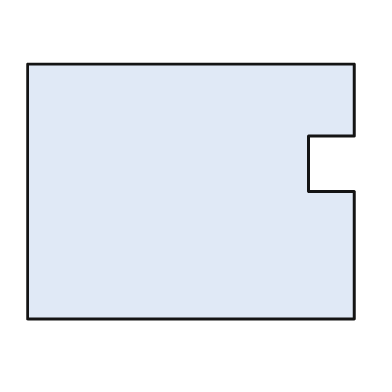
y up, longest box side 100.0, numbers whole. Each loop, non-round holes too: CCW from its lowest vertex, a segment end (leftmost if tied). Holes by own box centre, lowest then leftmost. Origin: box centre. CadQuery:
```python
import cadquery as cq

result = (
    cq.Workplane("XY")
    .moveTo(-50.0, -39.0)
    .lineTo(50.0, -39.0)
    .lineTo(50.0, 0.0)
    .lineTo(36.0, 0.0)
    .lineTo(36.0, 17.0)
    .lineTo(50.0, 17.0)
    .lineTo(50.0, 39.0)
    .lineTo(-50.0, 39.0)
    .close()
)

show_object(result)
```